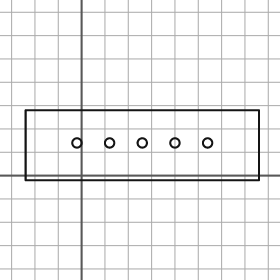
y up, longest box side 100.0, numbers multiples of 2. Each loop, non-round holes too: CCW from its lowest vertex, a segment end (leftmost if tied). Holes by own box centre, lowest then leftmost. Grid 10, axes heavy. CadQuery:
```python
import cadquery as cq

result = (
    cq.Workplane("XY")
    .moveTo(-24.0, -2.0)
    .lineTo(76.0, -2.0)
    .lineTo(76.0, 28.0)
    .lineTo(-24.0, 28.0)
    .close()
    .moveTo(-2.0, 14.0)
    .circle(2.0)
    .moveTo(12.0, 14.0)
    .circle(2.0)
    .moveTo(26.0, 14.0)
    .circle(2.0)
    .moveTo(40.0, 14.0)
    .circle(2.0)
    .moveTo(54.0, 14.0)
    .circle(2.0)
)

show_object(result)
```